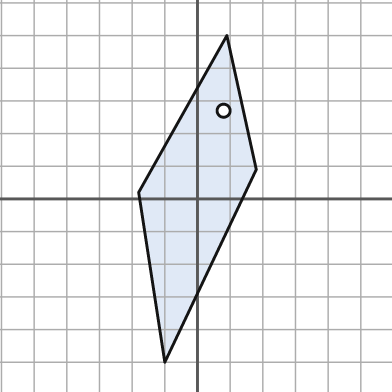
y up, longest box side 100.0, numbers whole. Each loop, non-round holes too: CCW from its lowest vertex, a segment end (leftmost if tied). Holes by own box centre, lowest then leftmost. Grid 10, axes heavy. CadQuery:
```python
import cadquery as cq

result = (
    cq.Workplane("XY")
    .moveTo(-10.0, -50.0)
    .lineTo(18.0, 9.0)
    .lineTo(9.0, 50.0)
    .lineTo(-18.0, 2.0)
    .close()
    .moveTo(8.0, 27.0)
    .circle(2.0)
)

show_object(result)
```